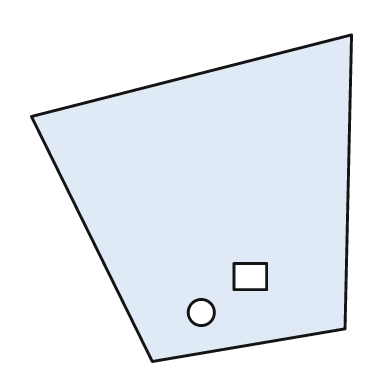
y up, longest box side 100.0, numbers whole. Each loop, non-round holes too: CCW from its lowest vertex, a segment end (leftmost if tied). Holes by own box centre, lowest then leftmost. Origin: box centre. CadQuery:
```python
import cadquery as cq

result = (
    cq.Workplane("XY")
    .moveTo(-12.0, -50.0)
    .lineTo(47.0, -40.0)
    .lineTo(49.0, 50.0)
    .lineTo(-49.0, 25.0)
    .close()
    .moveTo(3.0, -35.0)
    .circle(4.0)
    .moveTo(13.0, -28.0)
    .lineTo(23.0, -28.0)
    .lineTo(23.0, -20.0)
    .lineTo(13.0, -20.0)
    .close()
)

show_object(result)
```